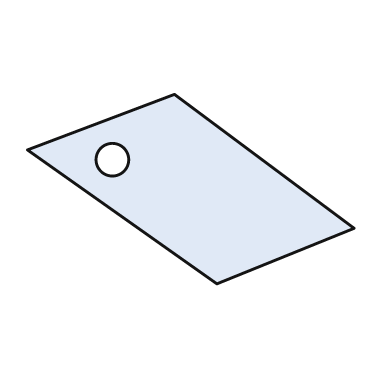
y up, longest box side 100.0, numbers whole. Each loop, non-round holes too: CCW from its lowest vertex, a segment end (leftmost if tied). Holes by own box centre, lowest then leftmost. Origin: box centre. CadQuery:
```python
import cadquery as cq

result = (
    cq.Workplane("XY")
    .moveTo(8.0, -29.0)
    .lineTo(50.0, -12.0)
    .lineTo(-5.0, 29.0)
    .lineTo(-50.0, 12.0)
    .close()
    .moveTo(-24.0, 9.0)
    .circle(5.0)
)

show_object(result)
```